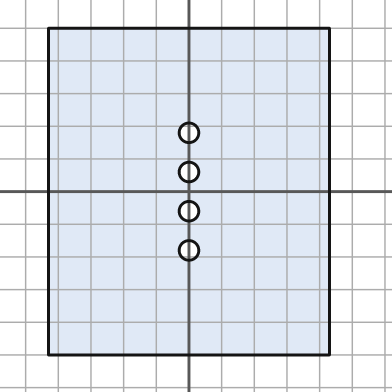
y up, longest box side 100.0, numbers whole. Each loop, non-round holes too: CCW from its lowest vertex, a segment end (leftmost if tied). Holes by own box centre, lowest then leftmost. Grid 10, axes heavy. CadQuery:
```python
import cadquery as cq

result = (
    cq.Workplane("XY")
    .moveTo(-43.0, -50.0)
    .lineTo(43.0, -50.0)
    .lineTo(43.0, 50.0)
    .lineTo(-43.0, 50.0)
    .close()
    .moveTo(0.0, -18.0)
    .circle(3.0)
    .moveTo(0.0, -6.0)
    .circle(3.0)
    .moveTo(0.0, 6.0)
    .circle(3.0)
    .moveTo(0.0, 18.0)
    .circle(3.0)
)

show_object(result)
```